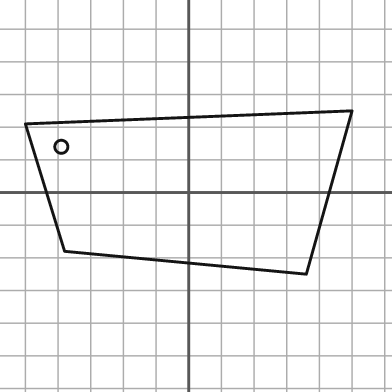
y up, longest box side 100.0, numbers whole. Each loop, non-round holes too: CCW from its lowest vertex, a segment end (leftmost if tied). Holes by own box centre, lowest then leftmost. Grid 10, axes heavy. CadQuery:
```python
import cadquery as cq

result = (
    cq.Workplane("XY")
    .moveTo(36.0, -25.0)
    .lineTo(50.0, 25.0)
    .lineTo(-50.0, 21.0)
    .lineTo(-38.0, -18.0)
    .close()
    .moveTo(-39.0, 14.0)
    .circle(2.0)
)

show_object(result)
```